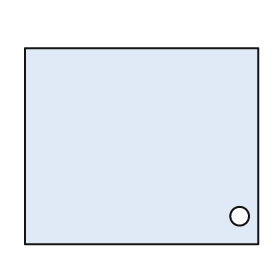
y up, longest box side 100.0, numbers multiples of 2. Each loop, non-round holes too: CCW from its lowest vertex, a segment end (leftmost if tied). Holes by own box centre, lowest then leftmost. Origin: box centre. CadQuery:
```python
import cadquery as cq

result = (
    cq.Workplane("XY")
    .moveTo(-50.0, -42.0)
    .lineTo(50.0, -42.0)
    .lineTo(50.0, 42.0)
    .lineTo(-50.0, 42.0)
    .close()
    .moveTo(42.0, -30.0)
    .circle(4.0)
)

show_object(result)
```